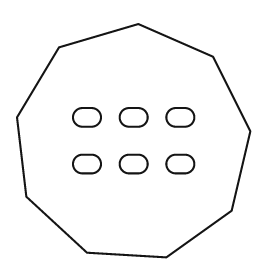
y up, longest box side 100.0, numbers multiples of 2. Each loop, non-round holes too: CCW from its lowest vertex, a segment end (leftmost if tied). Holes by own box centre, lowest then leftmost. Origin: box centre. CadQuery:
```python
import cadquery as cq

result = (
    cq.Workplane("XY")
    .moveTo(14.0, -50.0)
    .lineTo(42.0, -30.0)
    .lineTo(50.0, 4.0)
    .lineTo(34.0, 36.0)
    .lineTo(2.0, 50.0)
    .lineTo(-32.0, 40.0)
    .lineTo(-50.0, 10.0)
    .lineTo(-46.0, -24.0)
    .lineTo(-20.0, -48.0)
    .close()
    .moveTo(-22.0, -14.0)
    .lineTo(-18.0, -14.0)
    .threePointArc((-14.0, -10.0), (-18.0, -6.0))
    .lineTo(-22.0, -6.0)
    .threePointArc((-26.0, -10.0), (-22.0, -14.0))
    .close()
    .moveTo(-2.0, -14.0)
    .lineTo(2.0, -14.0)
    .threePointArc((6.0, -10.0), (2.0, -6.0))
    .lineTo(-2.0, -6.0)
    .threePointArc((-6.0, -10.0), (-2.0, -14.0))
    .close()
    .moveTo(18.0, -14.0)
    .lineTo(22.0, -14.0)
    .threePointArc((26.0, -10.0), (22.0, -6.0))
    .lineTo(18.0, -6.0)
    .threePointArc((14.0, -10.0), (18.0, -14.0))
    .close()
    .moveTo(-22.0, 6.0)
    .lineTo(-18.0, 6.0)
    .threePointArc((-14.0, 10.0), (-18.0, 14.0))
    .lineTo(-22.0, 14.0)
    .threePointArc((-26.0, 10.0), (-22.0, 6.0))
    .close()
    .moveTo(-2.0, 6.0)
    .lineTo(2.0, 6.0)
    .threePointArc((6.0, 10.0), (2.0, 14.0))
    .lineTo(-2.0, 14.0)
    .threePointArc((-6.0, 10.0), (-2.0, 6.0))
    .close()
    .moveTo(18.0, 6.0)
    .lineTo(22.0, 6.0)
    .threePointArc((26.0, 10.0), (22.0, 14.0))
    .lineTo(18.0, 14.0)
    .threePointArc((14.0, 10.0), (18.0, 6.0))
    .close()
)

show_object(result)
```